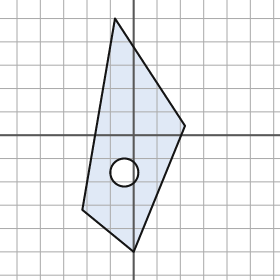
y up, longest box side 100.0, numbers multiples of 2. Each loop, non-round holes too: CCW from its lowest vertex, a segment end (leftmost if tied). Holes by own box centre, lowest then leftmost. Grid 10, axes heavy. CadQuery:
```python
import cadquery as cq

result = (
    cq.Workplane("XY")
    .moveTo(0.0, -50.0)
    .lineTo(22.0, 4.0)
    .lineTo(-8.0, 50.0)
    .lineTo(-22.0, -32.0)
    .close()
    .moveTo(-4.0, -16.0)
    .circle(6.0)
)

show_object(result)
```